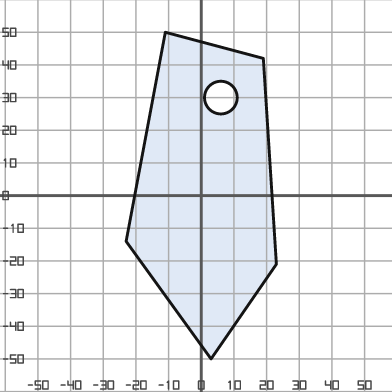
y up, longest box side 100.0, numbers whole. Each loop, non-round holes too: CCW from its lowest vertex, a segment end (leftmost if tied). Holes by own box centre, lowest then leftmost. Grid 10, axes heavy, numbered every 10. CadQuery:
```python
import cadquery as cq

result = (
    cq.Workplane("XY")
    .moveTo(3.0, -50.0)
    .lineTo(23.0, -21.0)
    .lineTo(19.0, 42.0)
    .lineTo(-11.0, 50.0)
    .lineTo(-23.0, -14.0)
    .close()
    .moveTo(6.0, 30.0)
    .circle(5.0)
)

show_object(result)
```